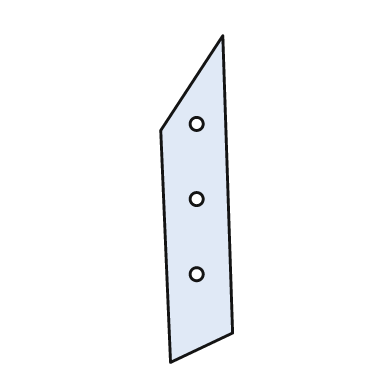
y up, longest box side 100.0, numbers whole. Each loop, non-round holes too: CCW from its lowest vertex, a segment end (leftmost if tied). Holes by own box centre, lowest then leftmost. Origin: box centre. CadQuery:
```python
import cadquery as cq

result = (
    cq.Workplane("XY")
    .moveTo(-8.0, -50.0)
    .lineTo(11.0, -41.0)
    .lineTo(8.0, 50.0)
    .lineTo(-11.0, 21.0)
    .close()
    .moveTo(0.0, -23.0)
    .circle(2.0)
    .moveTo(0.0, 0.0)
    .circle(2.0)
    .moveTo(0.0, 23.0)
    .circle(2.0)
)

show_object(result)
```